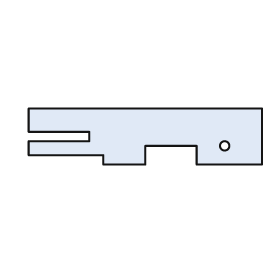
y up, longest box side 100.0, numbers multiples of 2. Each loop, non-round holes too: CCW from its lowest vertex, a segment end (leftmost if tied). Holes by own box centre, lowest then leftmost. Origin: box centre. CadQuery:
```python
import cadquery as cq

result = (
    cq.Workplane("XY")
    .moveTo(-18.0, -12.0)
    .lineTo(0.0, -12.0)
    .lineTo(0.0, -4.0)
    .lineTo(22.0, -4.0)
    .lineTo(22.0, -12.0)
    .lineTo(50.0, -12.0)
    .lineTo(50.0, 12.0)
    .lineTo(-50.0, 12.0)
    .lineTo(-50.0, 2.0)
    .lineTo(-24.0, 2.0)
    .lineTo(-24.0, -2.0)
    .lineTo(-50.0, -2.0)
    .lineTo(-50.0, -8.0)
    .lineTo(-18.0, -8.0)
    .close()
    .moveTo(34.0, -4.0)
    .circle(2.0)
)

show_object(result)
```